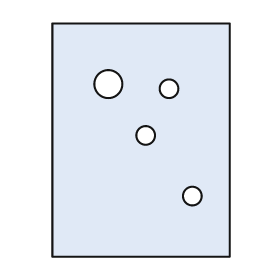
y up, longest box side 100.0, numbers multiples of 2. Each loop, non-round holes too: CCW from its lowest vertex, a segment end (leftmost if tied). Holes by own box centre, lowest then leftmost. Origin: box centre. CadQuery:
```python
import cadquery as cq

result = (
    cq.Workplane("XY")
    .moveTo(-38.0, -50.0)
    .lineTo(38.0, -50.0)
    .lineTo(38.0, 50.0)
    .lineTo(-38.0, 50.0)
    .close()
    .moveTo(22.0, -24.0)
    .circle(4.0)
    .moveTo(2.0, 2.0)
    .circle(4.0)
    .moveTo(12.0, 22.0)
    .circle(4.0)
    .moveTo(-14.0, 24.0)
    .circle(6.0)
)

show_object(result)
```